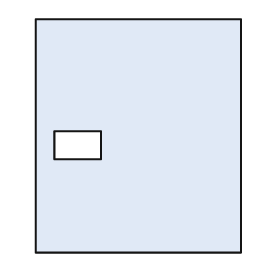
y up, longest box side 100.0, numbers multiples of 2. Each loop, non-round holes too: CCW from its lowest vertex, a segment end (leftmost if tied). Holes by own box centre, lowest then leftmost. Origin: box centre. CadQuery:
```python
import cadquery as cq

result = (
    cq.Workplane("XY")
    .moveTo(-44.0, -50.0)
    .lineTo(44.0, -50.0)
    .lineTo(44.0, 50.0)
    .lineTo(-44.0, 50.0)
    .close()
    .moveTo(-36.0, -10.0)
    .lineTo(-16.0, -10.0)
    .lineTo(-16.0, 2.0)
    .lineTo(-36.0, 2.0)
    .close()
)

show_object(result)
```